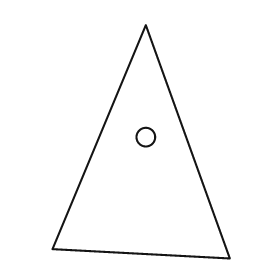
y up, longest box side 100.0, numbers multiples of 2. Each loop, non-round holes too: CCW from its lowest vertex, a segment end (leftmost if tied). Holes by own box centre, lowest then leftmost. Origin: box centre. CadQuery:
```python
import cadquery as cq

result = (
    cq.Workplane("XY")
    .moveTo(38.0, -50.0)
    .lineTo(2.0, 50.0)
    .lineTo(-38.0, -46.0)
    .close()
    .moveTo(2.0, 2.0)
    .circle(4.0)
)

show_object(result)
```